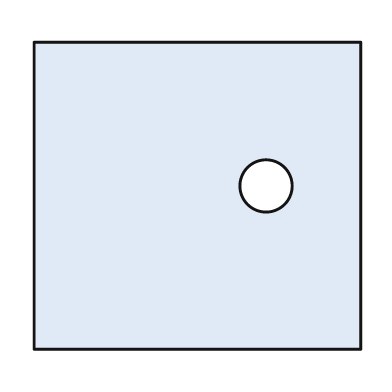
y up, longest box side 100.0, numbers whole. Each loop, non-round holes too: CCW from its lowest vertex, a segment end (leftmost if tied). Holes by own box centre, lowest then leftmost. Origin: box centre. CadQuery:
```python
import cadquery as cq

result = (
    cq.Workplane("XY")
    .moveTo(-50.0, -47.0)
    .lineTo(50.0, -47.0)
    .lineTo(50.0, 47.0)
    .lineTo(-50.0, 47.0)
    .close()
    .moveTo(21.0, 3.0)
    .circle(8.0)
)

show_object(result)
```